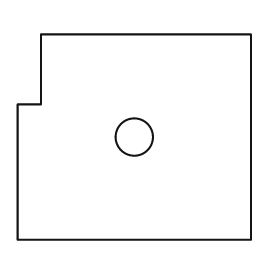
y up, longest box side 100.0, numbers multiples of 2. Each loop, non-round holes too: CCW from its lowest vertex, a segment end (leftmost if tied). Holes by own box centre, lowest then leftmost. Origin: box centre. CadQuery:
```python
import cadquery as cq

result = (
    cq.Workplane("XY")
    .moveTo(-50.0, -44.0)
    .lineTo(50.0, -44.0)
    .lineTo(50.0, 44.0)
    .lineTo(-40.0, 44.0)
    .lineTo(-40.0, 14.0)
    .lineTo(-50.0, 14.0)
    .close()
    .moveTo(0.0, 0.0)
    .circle(8.0)
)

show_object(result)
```